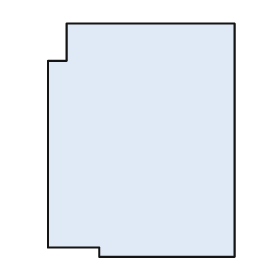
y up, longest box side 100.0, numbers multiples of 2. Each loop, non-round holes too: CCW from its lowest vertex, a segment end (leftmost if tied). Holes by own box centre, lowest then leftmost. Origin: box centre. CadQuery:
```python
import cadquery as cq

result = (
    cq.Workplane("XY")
    .moveTo(-18.0, -50.0)
    .lineTo(40.0, -50.0)
    .lineTo(40.0, 50.0)
    .lineTo(-32.0, 50.0)
    .lineTo(-32.0, 34.0)
    .lineTo(-40.0, 34.0)
    .lineTo(-40.0, -46.0)
    .lineTo(-18.0, -46.0)
    .close()
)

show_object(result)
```